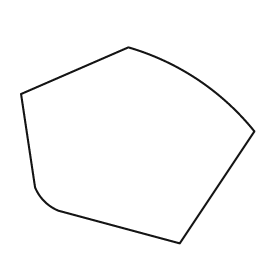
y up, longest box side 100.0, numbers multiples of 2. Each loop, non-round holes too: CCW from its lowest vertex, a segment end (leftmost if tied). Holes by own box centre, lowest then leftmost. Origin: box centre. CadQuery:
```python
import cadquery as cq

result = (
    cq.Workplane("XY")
    .moveTo(18.0, -42.0)
    .lineTo(50.0, 6.0)
    .threePointArc((26.0, 28.0), (-4.0, 42.0))
    .lineTo(-50.0, 22.0)
    .lineTo(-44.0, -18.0)
    .threePointArc((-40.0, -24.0), (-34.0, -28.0))
    .close()
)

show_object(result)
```